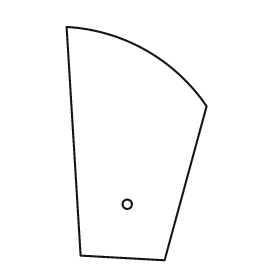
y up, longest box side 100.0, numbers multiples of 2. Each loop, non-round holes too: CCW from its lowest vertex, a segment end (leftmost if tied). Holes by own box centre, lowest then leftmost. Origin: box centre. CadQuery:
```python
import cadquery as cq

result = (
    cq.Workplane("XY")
    .moveTo(12.0, -50.0)
    .lineTo(30.0, 16.0)
    .threePointArc((4.0, 40.0), (-30.0, 50.0))
    .lineTo(-24.0, -48.0)
    .close()
    .moveTo(-4.0, -26.0)
    .circle(2.0)
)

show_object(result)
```